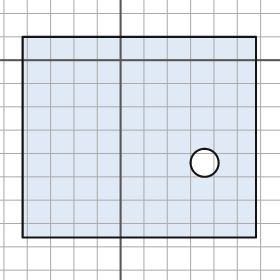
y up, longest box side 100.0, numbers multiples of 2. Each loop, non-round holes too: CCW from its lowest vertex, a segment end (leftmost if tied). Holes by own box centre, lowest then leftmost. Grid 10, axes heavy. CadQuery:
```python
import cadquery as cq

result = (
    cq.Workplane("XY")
    .moveTo(-42.0, -76.0)
    .lineTo(58.0, -76.0)
    .lineTo(58.0, 10.0)
    .lineTo(-42.0, 10.0)
    .close()
    .moveTo(36.0, -44.0)
    .circle(6.0)
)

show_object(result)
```